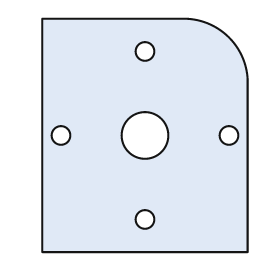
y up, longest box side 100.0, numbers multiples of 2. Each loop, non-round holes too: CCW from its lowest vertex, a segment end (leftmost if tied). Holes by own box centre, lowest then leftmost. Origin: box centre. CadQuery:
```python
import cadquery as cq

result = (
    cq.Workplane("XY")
    .moveTo(-44.0, -50.0)
    .lineTo(44.0, -50.0)
    .lineTo(44.0, 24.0)
    .threePointArc((36.0, 42.0), (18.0, 50.0))
    .lineTo(-44.0, 50.0)
    .close()
    .moveTo(0.0, -36.0)
    .circle(4.0)
    .moveTo(-36.0, 0.0)
    .circle(4.0)
    .moveTo(0.0, 0.0)
    .circle(10.0)
    .moveTo(36.0, 0.0)
    .circle(4.0)
    .moveTo(0.0, 36.0)
    .circle(4.0)
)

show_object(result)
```